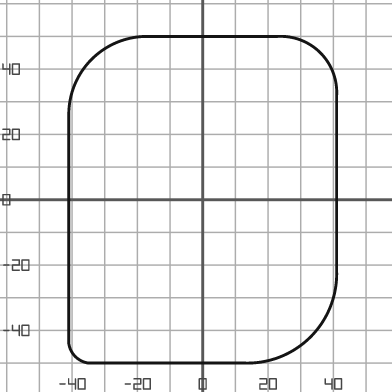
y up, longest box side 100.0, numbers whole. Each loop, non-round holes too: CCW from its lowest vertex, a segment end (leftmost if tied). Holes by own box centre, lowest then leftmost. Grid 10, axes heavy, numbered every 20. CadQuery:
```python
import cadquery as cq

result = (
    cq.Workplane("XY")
    .moveTo(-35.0, -50.0)
    .lineTo(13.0, -50.0)
    .threePointArc((33.0, -42.0), (41.0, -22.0))
    .lineTo(41.0, 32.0)
    .threePointArc((36.0, 45.0), (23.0, 50.0))
    .lineTo(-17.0, 50.0)
    .threePointArc((-34.0, 43.0), (-41.0, 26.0))
    .lineTo(-41.0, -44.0)
    .threePointArc((-39.0, -48.0), (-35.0, -50.0))
    .close()
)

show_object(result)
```